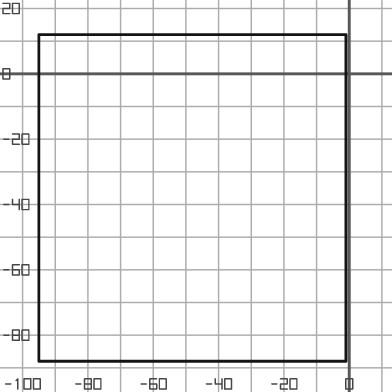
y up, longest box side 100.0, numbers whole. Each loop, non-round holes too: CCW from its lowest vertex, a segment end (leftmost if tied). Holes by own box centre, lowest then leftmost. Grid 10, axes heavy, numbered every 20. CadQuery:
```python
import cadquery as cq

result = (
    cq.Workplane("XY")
    .moveTo(-95.0, -88.0)
    .lineTo(-1.0, -88.0)
    .lineTo(-1.0, 12.0)
    .lineTo(-95.0, 12.0)
    .close()
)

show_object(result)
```